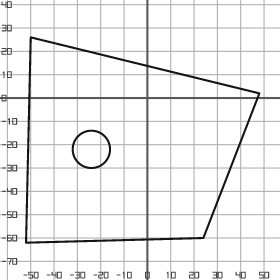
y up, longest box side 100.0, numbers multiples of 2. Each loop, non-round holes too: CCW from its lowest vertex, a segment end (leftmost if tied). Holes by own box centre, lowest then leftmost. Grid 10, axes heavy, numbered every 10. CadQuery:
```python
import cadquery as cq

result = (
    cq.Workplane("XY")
    .moveTo(-52.0, -62.0)
    .lineTo(24.0, -60.0)
    .lineTo(48.0, 2.0)
    .lineTo(-50.0, 26.0)
    .close()
    .moveTo(-24.0, -22.0)
    .circle(8.0)
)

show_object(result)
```